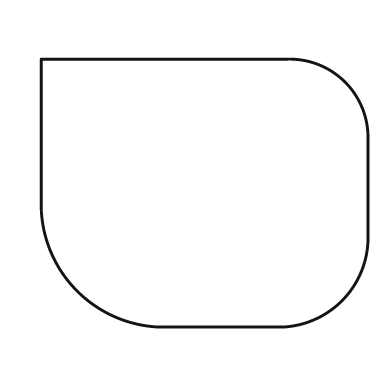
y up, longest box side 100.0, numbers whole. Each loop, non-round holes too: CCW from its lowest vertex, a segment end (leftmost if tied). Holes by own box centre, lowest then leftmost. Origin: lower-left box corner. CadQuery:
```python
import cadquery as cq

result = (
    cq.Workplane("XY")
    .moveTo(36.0, 0.0)
    .lineTo(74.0, 0.0)
    .threePointArc((92.0, 8.0), (100.0, 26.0))
    .lineTo(100.0, 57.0)
    .threePointArc((93.0, 75.0), (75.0, 82.0))
    .lineTo(0.0, 82.0)
    .lineTo(0.0, 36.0)
    .threePointArc((11.0, 11.0), (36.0, 0.0))
    .close()
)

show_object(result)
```